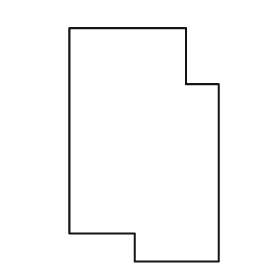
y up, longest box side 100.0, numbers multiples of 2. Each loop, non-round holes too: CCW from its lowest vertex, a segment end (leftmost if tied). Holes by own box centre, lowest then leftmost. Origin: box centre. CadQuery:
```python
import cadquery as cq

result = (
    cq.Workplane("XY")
    .moveTo(-4.0, -50.0)
    .lineTo(32.0, -50.0)
    .lineTo(32.0, 26.0)
    .lineTo(18.0, 26.0)
    .lineTo(18.0, 50.0)
    .lineTo(-32.0, 50.0)
    .lineTo(-32.0, -38.0)
    .lineTo(-4.0, -38.0)
    .close()
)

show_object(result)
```